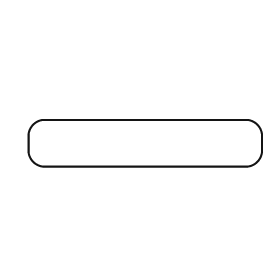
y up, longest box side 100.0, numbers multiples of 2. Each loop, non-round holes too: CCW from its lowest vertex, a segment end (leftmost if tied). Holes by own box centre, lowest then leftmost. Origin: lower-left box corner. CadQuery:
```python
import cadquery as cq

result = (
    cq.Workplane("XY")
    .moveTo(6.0, 0.0)
    .lineTo(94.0, 0.0)
    .threePointArc((98.0, 2.0), (100.0, 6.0))
    .lineTo(100.0, 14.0)
    .threePointArc((98.0, 18.0), (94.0, 20.0))
    .lineTo(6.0, 20.0)
    .threePointArc((2.0, 18.0), (0.0, 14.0))
    .lineTo(0.0, 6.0)
    .threePointArc((2.0, 2.0), (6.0, 0.0))
    .close()
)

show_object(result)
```